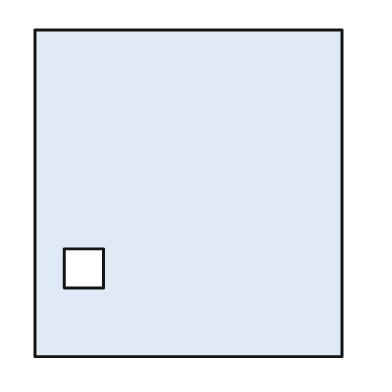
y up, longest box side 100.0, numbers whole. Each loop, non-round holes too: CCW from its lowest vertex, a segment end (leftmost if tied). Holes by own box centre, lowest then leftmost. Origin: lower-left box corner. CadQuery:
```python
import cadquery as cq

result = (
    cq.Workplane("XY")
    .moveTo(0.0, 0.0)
    .lineTo(94.0, 0.0)
    .lineTo(94.0, 100.0)
    .lineTo(0.0, 100.0)
    .close()
    .moveTo(9.0, 21.0)
    .lineTo(21.0, 21.0)
    .lineTo(21.0, 33.0)
    .lineTo(9.0, 33.0)
    .close()
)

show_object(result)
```